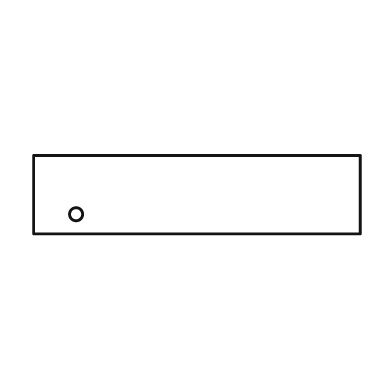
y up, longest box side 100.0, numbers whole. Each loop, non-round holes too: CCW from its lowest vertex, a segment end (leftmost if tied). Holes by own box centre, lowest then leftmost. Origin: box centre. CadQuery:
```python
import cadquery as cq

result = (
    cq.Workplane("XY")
    .moveTo(-50.0, -12.0)
    .lineTo(50.0, -12.0)
    .lineTo(50.0, 12.0)
    .lineTo(-50.0, 12.0)
    .close()
    .moveTo(-37.0, -6.0)
    .circle(2.0)
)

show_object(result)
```